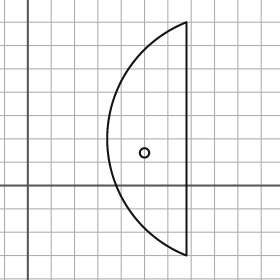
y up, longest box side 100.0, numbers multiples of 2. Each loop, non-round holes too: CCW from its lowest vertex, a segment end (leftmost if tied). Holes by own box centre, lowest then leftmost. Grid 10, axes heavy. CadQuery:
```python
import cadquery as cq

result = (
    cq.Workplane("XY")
    .moveTo(68.0, -30.0)
    .lineTo(68.0, 70.0)
    .threePointArc((34.0, 20.0), (68.0, -30.0))
    .close()
    .moveTo(50.0, 14.0)
    .circle(2.0)
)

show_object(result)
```